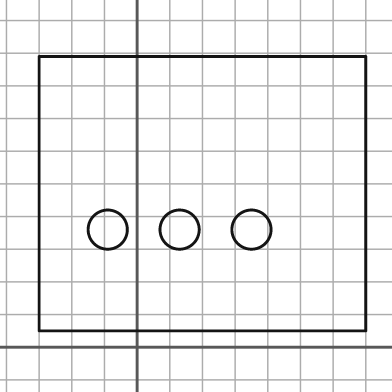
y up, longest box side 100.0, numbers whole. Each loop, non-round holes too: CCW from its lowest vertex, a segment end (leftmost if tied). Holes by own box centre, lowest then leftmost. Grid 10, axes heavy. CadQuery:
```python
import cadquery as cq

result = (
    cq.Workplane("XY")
    .moveTo(-30.0, 5.0)
    .lineTo(70.0, 5.0)
    .lineTo(70.0, 89.0)
    .lineTo(-30.0, 89.0)
    .close()
    .moveTo(-9.0, 36.0)
    .circle(6.0)
    .moveTo(13.0, 36.0)
    .circle(6.0)
    .moveTo(35.0, 36.0)
    .circle(6.0)
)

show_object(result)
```